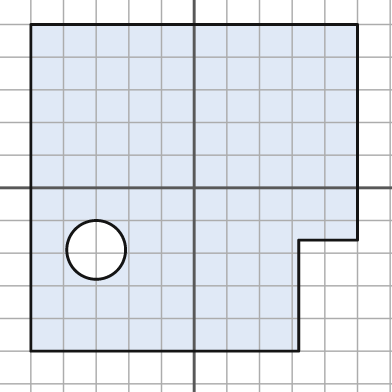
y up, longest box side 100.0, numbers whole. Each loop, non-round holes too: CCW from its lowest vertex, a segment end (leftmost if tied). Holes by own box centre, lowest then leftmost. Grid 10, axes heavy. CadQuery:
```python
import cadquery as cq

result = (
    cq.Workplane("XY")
    .moveTo(-50.0, -50.0)
    .lineTo(32.0, -50.0)
    .lineTo(32.0, -16.0)
    .lineTo(50.0, -16.0)
    .lineTo(50.0, 50.0)
    .lineTo(-50.0, 50.0)
    .close()
    .moveTo(-30.0, -19.0)
    .circle(9.0)
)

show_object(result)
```